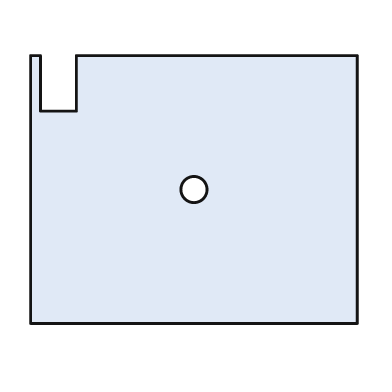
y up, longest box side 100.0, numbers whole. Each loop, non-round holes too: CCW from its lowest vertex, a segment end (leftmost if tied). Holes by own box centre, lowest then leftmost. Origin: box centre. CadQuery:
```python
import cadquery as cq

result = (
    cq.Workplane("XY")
    .moveTo(-50.0, -41.0)
    .lineTo(50.0, -41.0)
    .lineTo(50.0, 41.0)
    .lineTo(-36.0, 41.0)
    .lineTo(-36.0, 24.0)
    .lineTo(-47.0, 24.0)
    .lineTo(-47.0, 41.0)
    .lineTo(-50.0, 41.0)
    .close()
    .moveTo(0.0, 0.0)
    .circle(4.0)
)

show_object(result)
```